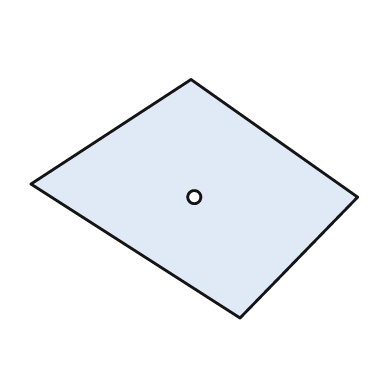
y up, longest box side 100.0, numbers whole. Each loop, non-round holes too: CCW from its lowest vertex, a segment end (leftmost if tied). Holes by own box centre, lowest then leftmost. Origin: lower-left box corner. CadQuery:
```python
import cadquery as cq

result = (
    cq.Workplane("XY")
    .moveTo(64.0, 0.0)
    .lineTo(100.0, 37.0)
    .lineTo(49.0, 73.0)
    .lineTo(0.0, 41.0)
    .close()
    .moveTo(50.0, 37.0)
    .circle(2.0)
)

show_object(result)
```